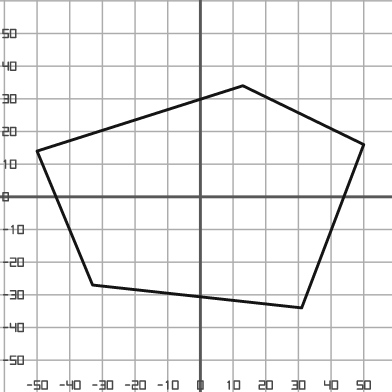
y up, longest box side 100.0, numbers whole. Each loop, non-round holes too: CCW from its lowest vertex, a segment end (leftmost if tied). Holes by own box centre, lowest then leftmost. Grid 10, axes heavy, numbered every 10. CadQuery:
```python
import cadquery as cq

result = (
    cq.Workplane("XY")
    .moveTo(31.0, -34.0)
    .lineTo(50.0, 16.0)
    .lineTo(13.0, 34.0)
    .lineTo(-50.0, 14.0)
    .lineTo(-33.0, -27.0)
    .close()
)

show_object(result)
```